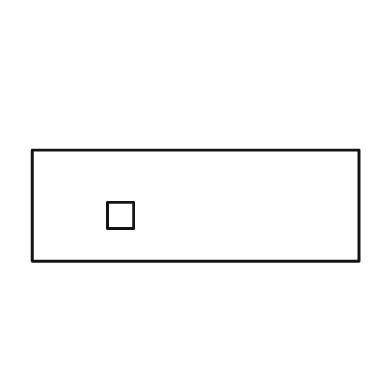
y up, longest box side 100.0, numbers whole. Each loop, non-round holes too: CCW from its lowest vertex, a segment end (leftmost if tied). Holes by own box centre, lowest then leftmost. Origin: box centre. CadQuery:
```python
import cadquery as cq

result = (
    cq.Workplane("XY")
    .moveTo(-50.0, -17.0)
    .lineTo(50.0, -17.0)
    .lineTo(50.0, 17.0)
    .lineTo(-50.0, 17.0)
    .close()
    .moveTo(-27.0, -7.0)
    .lineTo(-19.0, -7.0)
    .lineTo(-19.0, 1.0)
    .lineTo(-27.0, 1.0)
    .close()
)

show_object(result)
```